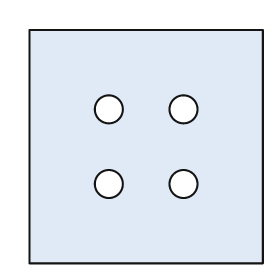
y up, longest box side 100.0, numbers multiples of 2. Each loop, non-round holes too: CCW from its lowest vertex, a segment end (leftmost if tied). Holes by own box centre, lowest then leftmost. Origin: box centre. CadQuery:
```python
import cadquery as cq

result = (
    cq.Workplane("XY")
    .moveTo(-50.0, -50.0)
    .lineTo(50.0, -50.0)
    .lineTo(50.0, 50.0)
    .lineTo(-50.0, 50.0)
    .close()
    .moveTo(-16.0, -16.0)
    .circle(6.0)
    .moveTo(16.0, -16.0)
    .circle(6.0)
    .moveTo(-16.0, 16.0)
    .circle(6.0)
    .moveTo(16.0, 16.0)
    .circle(6.0)
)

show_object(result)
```